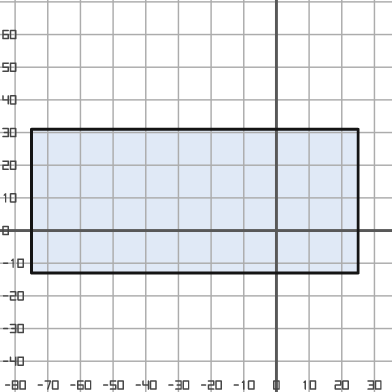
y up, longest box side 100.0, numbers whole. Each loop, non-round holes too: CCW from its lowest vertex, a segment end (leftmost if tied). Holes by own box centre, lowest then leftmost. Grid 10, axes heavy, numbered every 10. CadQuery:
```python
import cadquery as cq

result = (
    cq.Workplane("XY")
    .moveTo(-75.0, -13.0)
    .lineTo(25.0, -13.0)
    .lineTo(25.0, 31.0)
    .lineTo(-75.0, 31.0)
    .close()
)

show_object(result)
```